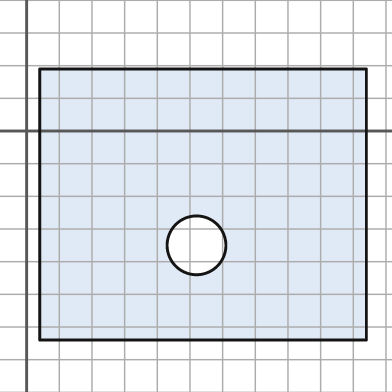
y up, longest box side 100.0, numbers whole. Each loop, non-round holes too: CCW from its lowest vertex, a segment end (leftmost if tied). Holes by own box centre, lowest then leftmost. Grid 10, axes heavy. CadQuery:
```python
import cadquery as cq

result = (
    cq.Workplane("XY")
    .moveTo(4.0, -64.0)
    .lineTo(104.0, -64.0)
    .lineTo(104.0, 19.0)
    .lineTo(4.0, 19.0)
    .close()
    .moveTo(52.0, -35.0)
    .circle(9.0)
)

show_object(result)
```